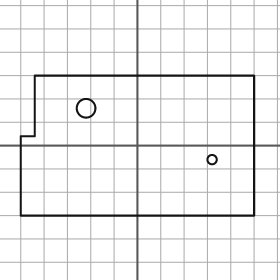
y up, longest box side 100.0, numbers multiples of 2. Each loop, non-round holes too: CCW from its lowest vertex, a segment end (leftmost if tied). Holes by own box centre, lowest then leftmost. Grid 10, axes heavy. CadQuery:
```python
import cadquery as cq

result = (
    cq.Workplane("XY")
    .moveTo(-50.0, -30.0)
    .lineTo(50.0, -30.0)
    .lineTo(50.0, 30.0)
    .lineTo(-44.0, 30.0)
    .lineTo(-44.0, 4.0)
    .lineTo(-50.0, 4.0)
    .close()
    .moveTo(32.0, -6.0)
    .circle(2.0)
    .moveTo(-22.0, 16.0)
    .circle(4.0)
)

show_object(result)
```